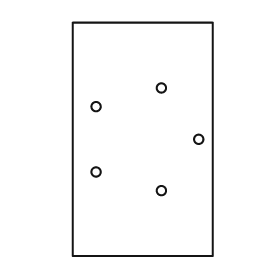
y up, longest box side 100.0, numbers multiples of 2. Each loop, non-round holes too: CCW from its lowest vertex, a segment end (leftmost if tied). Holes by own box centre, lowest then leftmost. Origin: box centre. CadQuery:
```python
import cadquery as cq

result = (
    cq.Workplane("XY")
    .moveTo(-30.0, -50.0)
    .lineTo(30.0, -50.0)
    .lineTo(30.0, 50.0)
    .lineTo(-30.0, 50.0)
    .close()
    .moveTo(8.0, -22.0)
    .circle(2.0)
    .moveTo(-20.0, -14.0)
    .circle(2.0)
    .moveTo(24.0, 0.0)
    .circle(2.0)
    .moveTo(-20.0, 14.0)
    .circle(2.0)
    .moveTo(8.0, 22.0)
    .circle(2.0)
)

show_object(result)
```